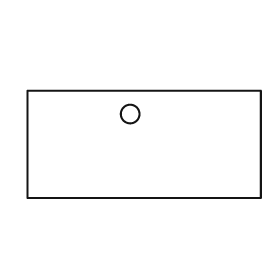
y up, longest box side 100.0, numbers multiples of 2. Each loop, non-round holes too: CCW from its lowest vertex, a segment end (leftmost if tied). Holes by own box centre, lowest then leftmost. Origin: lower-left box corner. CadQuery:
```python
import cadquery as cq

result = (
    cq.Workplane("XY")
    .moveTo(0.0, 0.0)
    .lineTo(100.0, 0.0)
    .lineTo(100.0, 46.0)
    .lineTo(0.0, 46.0)
    .close()
    .moveTo(44.0, 36.0)
    .circle(4.0)
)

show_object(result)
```